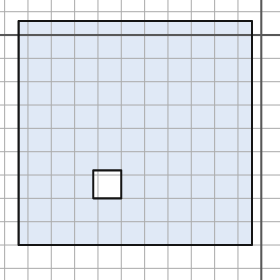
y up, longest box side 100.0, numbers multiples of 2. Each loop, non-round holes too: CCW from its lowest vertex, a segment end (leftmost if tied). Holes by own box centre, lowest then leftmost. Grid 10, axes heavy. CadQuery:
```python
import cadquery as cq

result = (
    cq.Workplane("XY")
    .moveTo(-104.0, -90.0)
    .lineTo(-4.0, -90.0)
    .lineTo(-4.0, 6.0)
    .lineTo(-104.0, 6.0)
    .close()
    .moveTo(-72.0, -70.0)
    .lineTo(-60.0, -70.0)
    .lineTo(-60.0, -58.0)
    .lineTo(-72.0, -58.0)
    .close()
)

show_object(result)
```